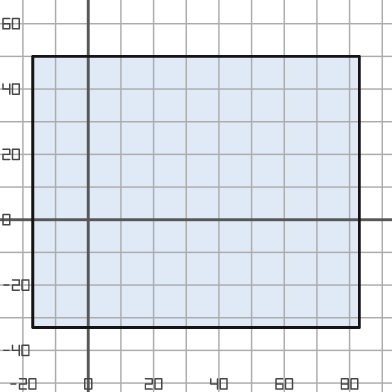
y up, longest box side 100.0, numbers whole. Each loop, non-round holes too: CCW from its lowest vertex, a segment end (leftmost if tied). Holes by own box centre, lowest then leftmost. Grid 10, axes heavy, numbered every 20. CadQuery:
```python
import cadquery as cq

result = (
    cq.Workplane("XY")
    .moveTo(-17.0, -33.0)
    .lineTo(83.0, -33.0)
    .lineTo(83.0, 50.0)
    .lineTo(-17.0, 50.0)
    .close()
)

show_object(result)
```